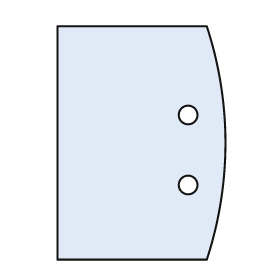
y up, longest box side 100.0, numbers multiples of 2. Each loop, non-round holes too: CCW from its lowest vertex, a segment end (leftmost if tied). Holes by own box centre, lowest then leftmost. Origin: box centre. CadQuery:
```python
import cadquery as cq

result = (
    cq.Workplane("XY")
    .moveTo(-36.0, -50.0)
    .lineTo(28.0, -50.0)
    .threePointArc((36.0, 0.0), (28.0, 50.0))
    .lineTo(-36.0, 50.0)
    .close()
    .moveTo(20.0, -18.0)
    .circle(4.0)
    .moveTo(20.0, 12.0)
    .circle(4.0)
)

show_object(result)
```